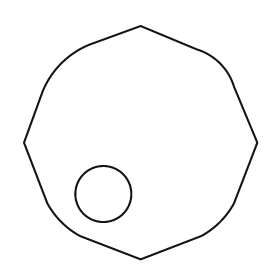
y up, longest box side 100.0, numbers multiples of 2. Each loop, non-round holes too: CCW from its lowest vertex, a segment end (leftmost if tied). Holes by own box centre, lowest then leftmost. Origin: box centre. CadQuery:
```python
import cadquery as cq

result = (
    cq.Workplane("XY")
    .moveTo(0.0, -50.0)
    .lineTo(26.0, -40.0)
    .threePointArc((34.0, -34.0), (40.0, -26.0))
    .lineTo(50.0, 0.0)
    .lineTo(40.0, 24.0)
    .threePointArc((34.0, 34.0), (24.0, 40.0))
    .lineTo(0.0, 50.0)
    .lineTo(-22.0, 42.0)
    .threePointArc((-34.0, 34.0), (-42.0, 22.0))
    .lineTo(-50.0, 0.0)
    .lineTo(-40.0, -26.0)
    .threePointArc((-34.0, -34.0), (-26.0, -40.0))
    .close()
    .moveTo(-16.0, -22.0)
    .circle(12.0)
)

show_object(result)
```